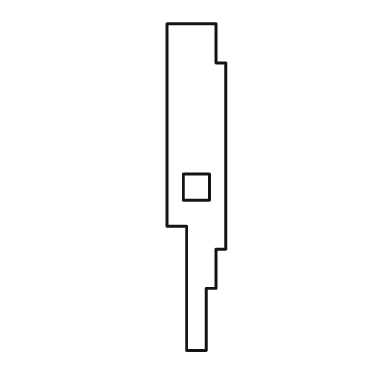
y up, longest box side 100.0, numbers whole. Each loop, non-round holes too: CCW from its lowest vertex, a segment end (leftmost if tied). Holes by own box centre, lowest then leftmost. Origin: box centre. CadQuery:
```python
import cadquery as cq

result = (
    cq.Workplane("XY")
    .moveTo(-3.0, -50.0)
    .lineTo(3.0, -50.0)
    .lineTo(3.0, -31.0)
    .lineTo(6.0, -31.0)
    .lineTo(6.0, -19.0)
    .lineTo(9.0, -19.0)
    .lineTo(9.0, 38.0)
    .lineTo(6.0, 38.0)
    .lineTo(6.0, 50.0)
    .lineTo(-9.0, 50.0)
    .lineTo(-9.0, -12.0)
    .lineTo(-3.0, -12.0)
    .close()
    .moveTo(-4.0, -4.0)
    .lineTo(4.0, -4.0)
    .lineTo(4.0, 4.0)
    .lineTo(-4.0, 4.0)
    .close()
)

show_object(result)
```